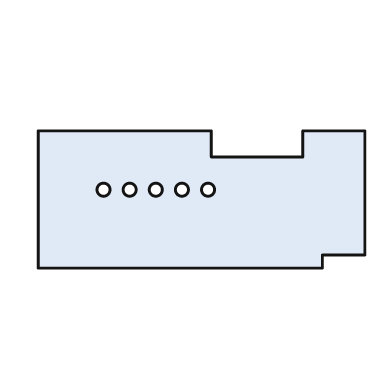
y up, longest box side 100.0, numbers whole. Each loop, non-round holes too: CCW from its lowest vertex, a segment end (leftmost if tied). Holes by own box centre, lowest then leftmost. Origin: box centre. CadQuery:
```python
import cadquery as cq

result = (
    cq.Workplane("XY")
    .moveTo(-50.0, -21.0)
    .lineTo(37.0, -21.0)
    .lineTo(37.0, -17.0)
    .lineTo(50.0, -17.0)
    .lineTo(50.0, 21.0)
    .lineTo(31.0, 21.0)
    .lineTo(31.0, 13.0)
    .lineTo(3.0, 13.0)
    .lineTo(3.0, 21.0)
    .lineTo(-50.0, 21.0)
    .close()
    .moveTo(-30.0, 3.0)
    .circle(2.0)
    .moveTo(-22.0, 3.0)
    .circle(2.0)
    .moveTo(-14.0, 3.0)
    .circle(2.0)
    .moveTo(-6.0, 3.0)
    .circle(2.0)
    .moveTo(2.0, 3.0)
    .circle(2.0)
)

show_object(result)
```